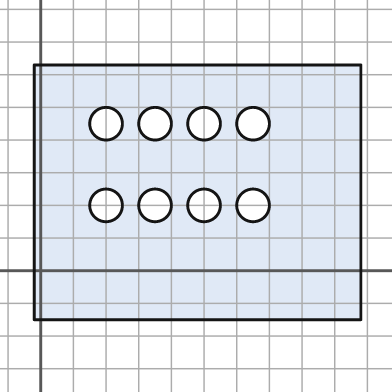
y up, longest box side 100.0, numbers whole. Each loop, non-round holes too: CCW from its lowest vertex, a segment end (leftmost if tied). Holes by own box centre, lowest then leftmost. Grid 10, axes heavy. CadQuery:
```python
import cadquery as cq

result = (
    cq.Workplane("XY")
    .moveTo(-2.0, -15.0)
    .lineTo(98.0, -15.0)
    .lineTo(98.0, 63.0)
    .lineTo(-2.0, 63.0)
    .close()
    .moveTo(20.0, 20.0)
    .circle(5.0)
    .moveTo(35.0, 20.0)
    .circle(5.0)
    .moveTo(50.0, 20.0)
    .circle(5.0)
    .moveTo(65.0, 20.0)
    .circle(5.0)
    .moveTo(20.0, 45.0)
    .circle(5.0)
    .moveTo(35.0, 45.0)
    .circle(5.0)
    .moveTo(50.0, 45.0)
    .circle(5.0)
    .moveTo(65.0, 45.0)
    .circle(5.0)
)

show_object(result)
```